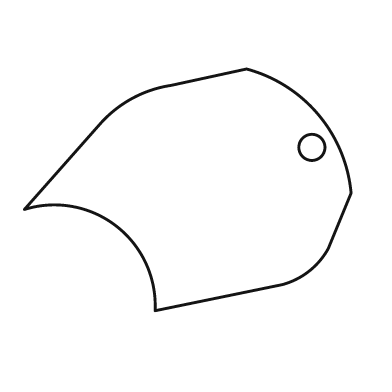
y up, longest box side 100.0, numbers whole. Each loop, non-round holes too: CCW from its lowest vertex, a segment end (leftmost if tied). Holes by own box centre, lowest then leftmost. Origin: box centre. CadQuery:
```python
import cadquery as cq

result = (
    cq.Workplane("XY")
    .moveTo(-10.0, -37.0)
    .lineTo(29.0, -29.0)
    .threePointArc((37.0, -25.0), (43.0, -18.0))
    .lineTo(50.0, -1.0)
    .threePointArc((40.0, 23.0), (18.0, 37.0))
    .lineTo(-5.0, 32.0)
    .threePointArc((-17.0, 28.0), (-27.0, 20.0))
    .lineTo(-50.0, -6.0)
    .threePointArc((-22.0, -11.0), (-10.0, -37.0))
    .close()
    .moveTo(38.0, 13.0)
    .circle(4.0)
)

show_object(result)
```